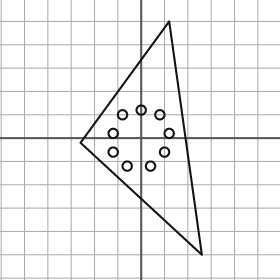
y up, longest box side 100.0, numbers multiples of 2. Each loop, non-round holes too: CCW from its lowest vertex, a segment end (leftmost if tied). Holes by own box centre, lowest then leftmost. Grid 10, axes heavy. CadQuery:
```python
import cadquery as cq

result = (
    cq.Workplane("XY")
    .moveTo(26.0, -50.0)
    .lineTo(12.0, 50.0)
    .lineTo(-26.0, -2.0)
    .close()
    .moveTo(-6.0, -12.0)
    .circle(2.0)
    .moveTo(4.0, -12.0)
    .circle(2.0)
    .moveTo(-12.0, -6.0)
    .circle(2.0)
    .moveTo(10.0, -6.0)
    .circle(2.0)
    .moveTo(-12.0, 2.0)
    .circle(2.0)
    .moveTo(12.0, 2.0)
    .circle(2.0)
    .moveTo(-8.0, 10.0)
    .circle(2.0)
    .moveTo(8.0, 10.0)
    .circle(2.0)
    .moveTo(0.0, 12.0)
    .circle(2.0)
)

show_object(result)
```